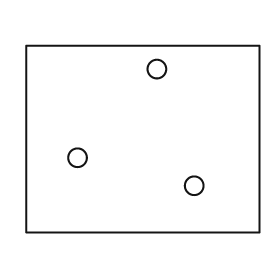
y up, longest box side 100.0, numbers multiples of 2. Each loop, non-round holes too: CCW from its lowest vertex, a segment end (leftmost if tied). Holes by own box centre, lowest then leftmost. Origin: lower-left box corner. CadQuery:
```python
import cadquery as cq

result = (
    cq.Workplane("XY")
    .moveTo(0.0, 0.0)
    .lineTo(100.0, 0.0)
    .lineTo(100.0, 80.0)
    .lineTo(0.0, 80.0)
    .close()
    .moveTo(72.0, 20.0)
    .circle(4.0)
    .moveTo(22.0, 32.0)
    .circle(4.0)
    .moveTo(56.0, 70.0)
    .circle(4.0)
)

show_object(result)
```